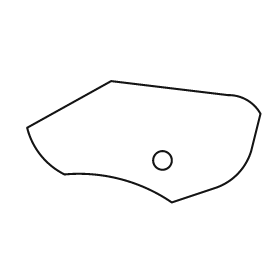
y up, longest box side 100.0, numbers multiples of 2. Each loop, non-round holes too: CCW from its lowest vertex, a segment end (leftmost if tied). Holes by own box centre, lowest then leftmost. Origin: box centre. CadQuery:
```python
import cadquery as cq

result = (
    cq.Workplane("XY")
    .moveTo(12.0, -26.0)
    .lineTo(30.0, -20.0)
    .threePointArc((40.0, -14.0), (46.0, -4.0))
    .lineTo(50.0, 12.0)
    .threePointArc((44.0, 18.0), (36.0, 20.0))
    .lineTo(-14.0, 26.0)
    .lineTo(-50.0, 6.0)
    .threePointArc((-44.0, -6.0), (-34.0, -14.0))
    .threePointArc((-10.0, -16.0), (12.0, -26.0))
    .close()
    .moveTo(8.0, -8.0)
    .circle(4.0)
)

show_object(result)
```